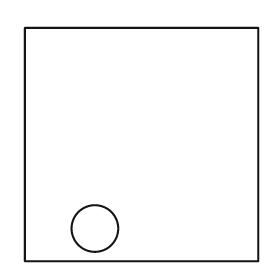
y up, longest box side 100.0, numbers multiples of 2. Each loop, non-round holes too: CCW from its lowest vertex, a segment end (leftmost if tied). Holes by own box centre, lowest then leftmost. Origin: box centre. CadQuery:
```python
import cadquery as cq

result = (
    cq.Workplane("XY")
    .moveTo(-50.0, -50.0)
    .lineTo(50.0, -50.0)
    .lineTo(50.0, 50.0)
    .lineTo(-50.0, 50.0)
    .close()
    .moveTo(-20.0, -36.0)
    .circle(10.0)
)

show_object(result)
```